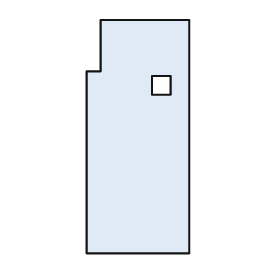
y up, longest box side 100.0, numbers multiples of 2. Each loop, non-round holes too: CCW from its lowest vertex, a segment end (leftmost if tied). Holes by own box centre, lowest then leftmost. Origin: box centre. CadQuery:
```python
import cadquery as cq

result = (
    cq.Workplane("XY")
    .moveTo(-22.0, -50.0)
    .lineTo(22.0, -50.0)
    .lineTo(22.0, 50.0)
    .lineTo(-16.0, 50.0)
    .lineTo(-16.0, 28.0)
    .lineTo(-22.0, 28.0)
    .close()
    .moveTo(6.0, 18.0)
    .lineTo(14.0, 18.0)
    .lineTo(14.0, 26.0)
    .lineTo(6.0, 26.0)
    .close()
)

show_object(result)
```